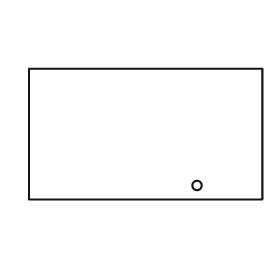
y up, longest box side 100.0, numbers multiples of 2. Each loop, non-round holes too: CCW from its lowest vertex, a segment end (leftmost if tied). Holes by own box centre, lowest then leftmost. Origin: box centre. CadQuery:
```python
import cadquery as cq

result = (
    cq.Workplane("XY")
    .moveTo(-50.0, -28.0)
    .lineTo(50.0, -28.0)
    .lineTo(50.0, 28.0)
    .lineTo(-50.0, 28.0)
    .close()
    .moveTo(22.0, -22.0)
    .circle(2.0)
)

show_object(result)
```